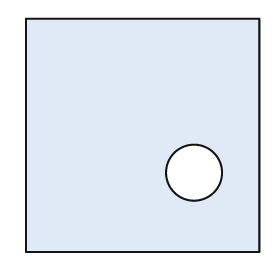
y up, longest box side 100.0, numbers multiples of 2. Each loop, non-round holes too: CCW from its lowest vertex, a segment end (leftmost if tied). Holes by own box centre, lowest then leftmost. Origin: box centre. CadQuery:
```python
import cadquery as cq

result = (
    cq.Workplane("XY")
    .moveTo(-50.0, -50.0)
    .lineTo(50.0, -50.0)
    .lineTo(50.0, 50.0)
    .lineTo(-50.0, 50.0)
    .close()
    .moveTo(22.0, -16.0)
    .circle(12.0)
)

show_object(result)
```